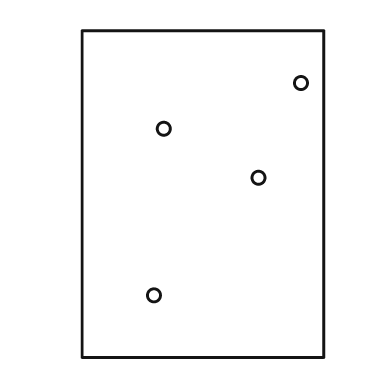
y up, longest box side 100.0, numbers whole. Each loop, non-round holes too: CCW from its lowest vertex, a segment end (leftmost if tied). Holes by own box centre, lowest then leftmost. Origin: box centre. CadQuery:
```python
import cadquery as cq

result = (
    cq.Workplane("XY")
    .moveTo(-37.0, -50.0)
    .lineTo(37.0, -50.0)
    .lineTo(37.0, 50.0)
    .lineTo(-37.0, 50.0)
    .close()
    .moveTo(-15.0, -31.0)
    .circle(2.0)
    .moveTo(17.0, 5.0)
    .circle(2.0)
    .moveTo(-12.0, 20.0)
    .circle(2.0)
    .moveTo(30.0, 34.0)
    .circle(2.0)
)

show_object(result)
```